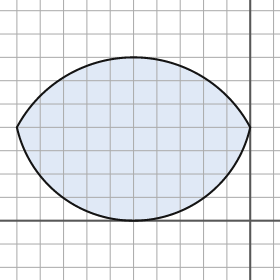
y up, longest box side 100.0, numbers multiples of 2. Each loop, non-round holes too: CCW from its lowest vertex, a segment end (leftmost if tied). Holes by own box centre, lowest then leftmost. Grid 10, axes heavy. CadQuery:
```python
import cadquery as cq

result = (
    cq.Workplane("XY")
    .moveTo(-100.0, 40.0)
    .threePointArc((-50.0, 0.0), (0.0, 40.0))
    .threePointArc((-50.0, 70.0), (-100.0, 40.0))
    .close()
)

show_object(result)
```